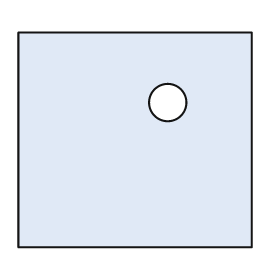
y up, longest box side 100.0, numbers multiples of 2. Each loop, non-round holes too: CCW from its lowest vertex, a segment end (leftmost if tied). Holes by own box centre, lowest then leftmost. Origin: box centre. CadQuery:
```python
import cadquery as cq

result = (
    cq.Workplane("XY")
    .moveTo(-50.0, -46.0)
    .lineTo(50.0, -46.0)
    .lineTo(50.0, 46.0)
    .lineTo(-50.0, 46.0)
    .close()
    .moveTo(14.0, 16.0)
    .circle(8.0)
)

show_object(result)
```